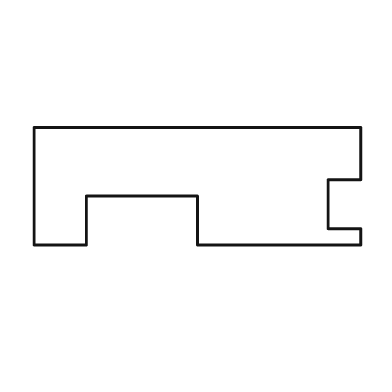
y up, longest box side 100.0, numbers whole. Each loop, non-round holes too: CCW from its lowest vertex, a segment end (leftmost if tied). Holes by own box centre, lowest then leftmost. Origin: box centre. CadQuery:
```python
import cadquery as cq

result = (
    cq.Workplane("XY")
    .moveTo(-50.0, -18.0)
    .lineTo(-34.0, -18.0)
    .lineTo(-34.0, -3.0)
    .lineTo(0.0, -3.0)
    .lineTo(0.0, -18.0)
    .lineTo(50.0, -18.0)
    .lineTo(50.0, -13.0)
    .lineTo(40.0, -13.0)
    .lineTo(40.0, 2.0)
    .lineTo(50.0, 2.0)
    .lineTo(50.0, 18.0)
    .lineTo(-50.0, 18.0)
    .close()
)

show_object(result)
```